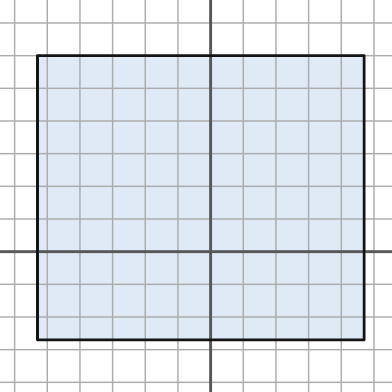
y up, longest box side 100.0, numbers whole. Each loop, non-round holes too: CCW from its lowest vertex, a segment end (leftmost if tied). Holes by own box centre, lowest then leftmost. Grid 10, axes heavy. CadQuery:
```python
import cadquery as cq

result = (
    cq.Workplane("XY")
    .moveTo(-53.0, -27.0)
    .lineTo(47.0, -27.0)
    .lineTo(47.0, 60.0)
    .lineTo(-53.0, 60.0)
    .close()
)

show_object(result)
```